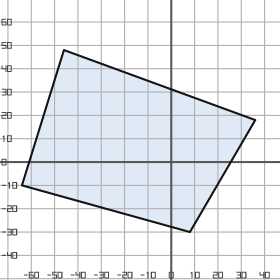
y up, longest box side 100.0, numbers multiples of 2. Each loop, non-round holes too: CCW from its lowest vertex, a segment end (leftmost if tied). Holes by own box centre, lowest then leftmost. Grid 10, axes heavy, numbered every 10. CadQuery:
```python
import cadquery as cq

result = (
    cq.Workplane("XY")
    .moveTo(8.0, -30.0)
    .lineTo(36.0, 18.0)
    .lineTo(-46.0, 48.0)
    .lineTo(-64.0, -10.0)
    .close()
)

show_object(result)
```